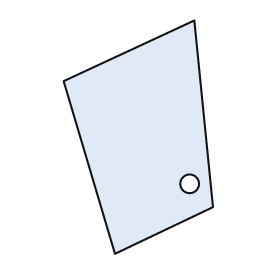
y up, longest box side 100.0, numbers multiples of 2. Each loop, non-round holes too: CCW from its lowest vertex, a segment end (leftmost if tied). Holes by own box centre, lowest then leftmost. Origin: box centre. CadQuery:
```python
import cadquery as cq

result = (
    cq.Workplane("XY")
    .moveTo(-10.0, -50.0)
    .lineTo(32.0, -30.0)
    .lineTo(24.0, 50.0)
    .lineTo(-32.0, 24.0)
    .close()
    .moveTo(22.0, -20.0)
    .circle(4.0)
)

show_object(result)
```